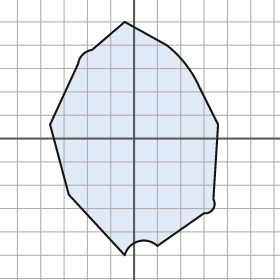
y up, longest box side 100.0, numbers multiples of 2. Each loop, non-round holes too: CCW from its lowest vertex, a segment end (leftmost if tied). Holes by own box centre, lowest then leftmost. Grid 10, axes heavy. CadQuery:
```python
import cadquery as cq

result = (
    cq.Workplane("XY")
    .moveTo(-4.0, -50.0)
    .threePointArc((2.0, -44.0), (10.0, -46.0))
    .lineTo(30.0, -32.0)
    .threePointArc((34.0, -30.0), (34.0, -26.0))
    .lineTo(36.0, 6.0)
    .lineTo(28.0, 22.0)
    .threePointArc((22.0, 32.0), (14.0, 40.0))
    .lineTo(-4.0, 50.0)
    .lineTo(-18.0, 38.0)
    .threePointArc((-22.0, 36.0), (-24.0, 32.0))
    .lineTo(-36.0, 6.0)
    .lineTo(-28.0, -24.0)
    .close()
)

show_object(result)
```